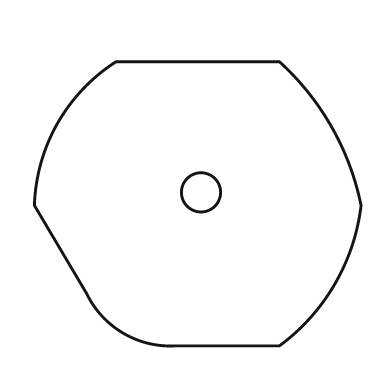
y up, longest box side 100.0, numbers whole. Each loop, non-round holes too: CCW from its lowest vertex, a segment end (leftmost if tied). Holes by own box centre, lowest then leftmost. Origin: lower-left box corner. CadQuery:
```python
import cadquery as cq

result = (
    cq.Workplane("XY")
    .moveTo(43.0, 0.0)
    .lineTo(75.0, 0.0)
    .threePointArc((92.0, 19.0), (100.0, 43.0))
    .threePointArc((91.0, 67.0), (75.0, 87.0))
    .lineTo(25.0, 87.0)
    .threePointArc((7.0, 68.0), (0.0, 43.0))
    .lineTo(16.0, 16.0)
    .threePointArc((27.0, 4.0), (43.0, 0.0))
    .close()
    .moveTo(51.0, 47.0)
    .circle(6.0)
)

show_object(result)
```